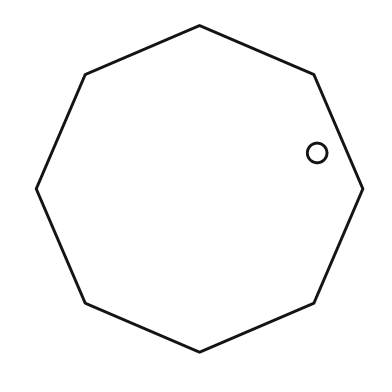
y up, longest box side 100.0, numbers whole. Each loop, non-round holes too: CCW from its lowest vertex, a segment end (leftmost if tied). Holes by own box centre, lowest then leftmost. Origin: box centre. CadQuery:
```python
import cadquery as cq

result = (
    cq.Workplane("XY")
    .moveTo(0.0, -50.0)
    .lineTo(35.0, -35.0)
    .lineTo(50.0, 0.0)
    .lineTo(35.0, 35.0)
    .lineTo(0.0, 50.0)
    .lineTo(-35.0, 35.0)
    .lineTo(-50.0, 0.0)
    .lineTo(-35.0, -35.0)
    .close()
    .moveTo(36.0, 11.0)
    .circle(3.0)
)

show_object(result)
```